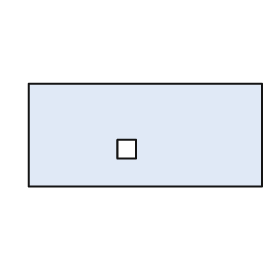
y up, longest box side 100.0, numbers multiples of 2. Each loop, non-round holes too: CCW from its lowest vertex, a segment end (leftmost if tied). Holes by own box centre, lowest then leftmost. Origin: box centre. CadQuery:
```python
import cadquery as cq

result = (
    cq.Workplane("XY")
    .moveTo(-50.0, -22.0)
    .lineTo(50.0, -22.0)
    .lineTo(50.0, 22.0)
    .lineTo(-50.0, 22.0)
    .close()
    .moveTo(-12.0, -10.0)
    .lineTo(-4.0, -10.0)
    .lineTo(-4.0, -2.0)
    .lineTo(-12.0, -2.0)
    .close()
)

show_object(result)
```